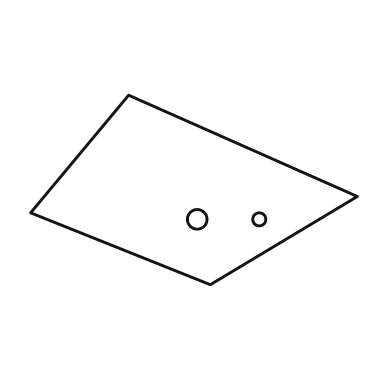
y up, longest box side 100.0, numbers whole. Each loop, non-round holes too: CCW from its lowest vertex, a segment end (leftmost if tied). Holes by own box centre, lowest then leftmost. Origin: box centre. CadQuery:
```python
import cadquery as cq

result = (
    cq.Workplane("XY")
    .moveTo(5.0, -29.0)
    .lineTo(50.0, -2.0)
    .lineTo(-20.0, 29.0)
    .lineTo(-50.0, -7.0)
    .close()
    .moveTo(1.0, -9.0)
    .circle(3.0)
    .moveTo(20.0, -9.0)
    .circle(2.0)
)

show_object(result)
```